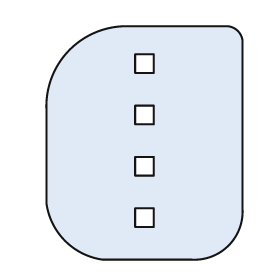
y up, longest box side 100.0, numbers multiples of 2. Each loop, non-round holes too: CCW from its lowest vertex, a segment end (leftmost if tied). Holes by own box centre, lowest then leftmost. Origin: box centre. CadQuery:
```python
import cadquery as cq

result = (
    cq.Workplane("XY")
    .moveTo(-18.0, -50.0)
    .lineTo(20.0, -50.0)
    .threePointArc((36.0, -44.0), (42.0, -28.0))
    .lineTo(42.0, 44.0)
    .threePointArc((40.0, 48.0), (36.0, 50.0))
    .lineTo(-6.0, 50.0)
    .threePointArc((-32.0, 40.0), (-42.0, 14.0))
    .lineTo(-42.0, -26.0)
    .threePointArc((-34.0, -42.0), (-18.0, -50.0))
    .close()
    .moveTo(-4.0, -36.0)
    .lineTo(4.0, -36.0)
    .lineTo(4.0, -28.0)
    .lineTo(-4.0, -28.0)
    .close()
    .moveTo(-4.0, -14.0)
    .lineTo(4.0, -14.0)
    .lineTo(4.0, -6.0)
    .lineTo(-4.0, -6.0)
    .close()
    .moveTo(-4.0, 8.0)
    .lineTo(4.0, 8.0)
    .lineTo(4.0, 16.0)
    .lineTo(-4.0, 16.0)
    .close()
    .moveTo(-4.0, 30.0)
    .lineTo(4.0, 30.0)
    .lineTo(4.0, 38.0)
    .lineTo(-4.0, 38.0)
    .close()
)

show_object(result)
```